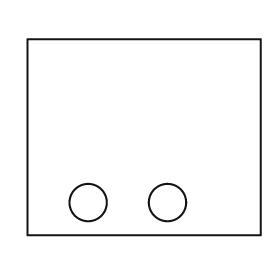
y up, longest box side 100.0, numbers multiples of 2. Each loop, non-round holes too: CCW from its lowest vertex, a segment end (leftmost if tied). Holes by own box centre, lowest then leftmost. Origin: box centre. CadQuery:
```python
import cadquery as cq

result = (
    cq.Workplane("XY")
    .moveTo(-50.0, -42.0)
    .lineTo(50.0, -42.0)
    .lineTo(50.0, 42.0)
    .lineTo(-50.0, 42.0)
    .close()
    .moveTo(-24.0, -28.0)
    .circle(8.0)
    .moveTo(10.0, -28.0)
    .circle(8.0)
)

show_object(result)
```